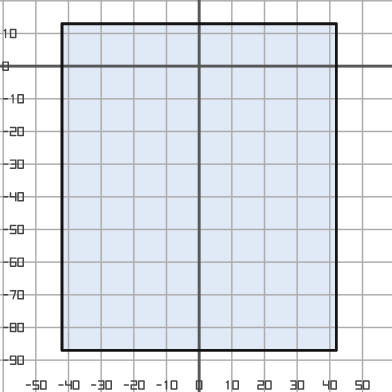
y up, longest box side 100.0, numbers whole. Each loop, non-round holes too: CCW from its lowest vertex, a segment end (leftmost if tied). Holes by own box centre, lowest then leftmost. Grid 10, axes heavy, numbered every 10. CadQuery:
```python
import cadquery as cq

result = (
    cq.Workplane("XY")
    .moveTo(-42.0, -87.0)
    .lineTo(42.0, -87.0)
    .lineTo(42.0, 13.0)
    .lineTo(-42.0, 13.0)
    .close()
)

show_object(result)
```